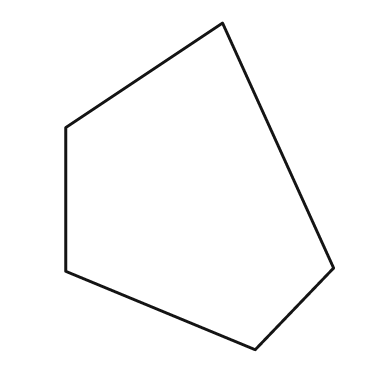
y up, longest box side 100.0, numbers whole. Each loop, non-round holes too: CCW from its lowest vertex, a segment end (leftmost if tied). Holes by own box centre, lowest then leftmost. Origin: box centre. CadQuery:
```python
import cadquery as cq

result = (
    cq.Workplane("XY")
    .moveTo(17.0, -50.0)
    .lineTo(41.0, -25.0)
    .lineTo(7.0, 50.0)
    .lineTo(-41.0, 18.0)
    .lineTo(-41.0, -26.0)
    .close()
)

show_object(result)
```